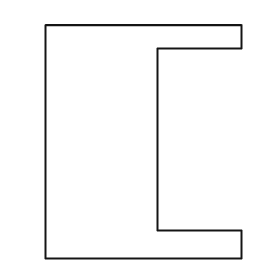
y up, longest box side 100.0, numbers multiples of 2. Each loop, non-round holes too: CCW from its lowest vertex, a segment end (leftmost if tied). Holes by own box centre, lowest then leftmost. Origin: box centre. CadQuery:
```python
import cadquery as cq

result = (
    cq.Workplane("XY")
    .moveTo(-42.0, -50.0)
    .lineTo(42.0, -50.0)
    .lineTo(42.0, -38.0)
    .lineTo(6.0, -38.0)
    .lineTo(6.0, 40.0)
    .lineTo(42.0, 40.0)
    .lineTo(42.0, 50.0)
    .lineTo(-42.0, 50.0)
    .close()
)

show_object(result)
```